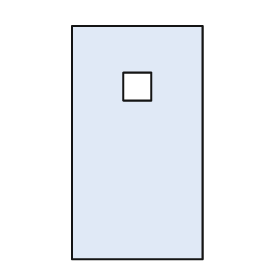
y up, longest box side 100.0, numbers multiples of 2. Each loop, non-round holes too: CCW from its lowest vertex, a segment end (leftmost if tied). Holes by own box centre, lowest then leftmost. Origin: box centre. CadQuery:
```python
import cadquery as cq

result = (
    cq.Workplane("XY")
    .moveTo(-28.0, -50.0)
    .lineTo(28.0, -50.0)
    .lineTo(28.0, 50.0)
    .lineTo(-28.0, 50.0)
    .close()
    .moveTo(-6.0, 18.0)
    .lineTo(6.0, 18.0)
    .lineTo(6.0, 30.0)
    .lineTo(-6.0, 30.0)
    .close()
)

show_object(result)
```